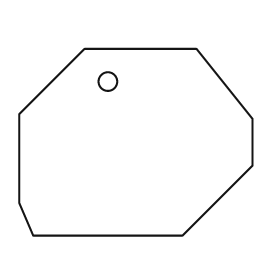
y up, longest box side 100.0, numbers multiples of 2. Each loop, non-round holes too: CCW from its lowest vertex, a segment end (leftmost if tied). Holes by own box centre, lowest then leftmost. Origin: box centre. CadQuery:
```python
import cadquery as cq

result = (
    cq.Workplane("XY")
    .moveTo(-44.0, -40.0)
    .lineTo(20.0, -40.0)
    .lineTo(50.0, -10.0)
    .lineTo(50.0, 10.0)
    .lineTo(26.0, 40.0)
    .lineTo(-22.0, 40.0)
    .lineTo(-50.0, 12.0)
    .lineTo(-50.0, -26.0)
    .close()
    .moveTo(-12.0, 26.0)
    .circle(4.0)
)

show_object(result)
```